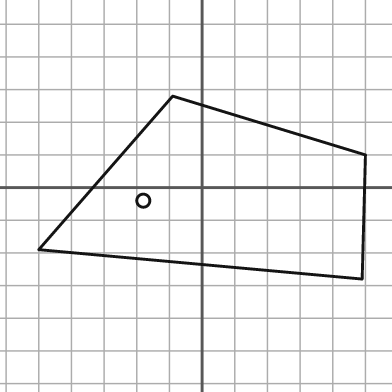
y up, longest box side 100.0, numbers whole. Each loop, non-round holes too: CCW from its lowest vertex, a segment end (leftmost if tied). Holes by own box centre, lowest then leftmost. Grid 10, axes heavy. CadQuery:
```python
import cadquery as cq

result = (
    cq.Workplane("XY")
    .moveTo(49.0, -28.0)
    .lineTo(50.0, 10.0)
    .lineTo(-9.0, 28.0)
    .lineTo(-50.0, -19.0)
    .close()
    .moveTo(-18.0, -4.0)
    .circle(2.0)
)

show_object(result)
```